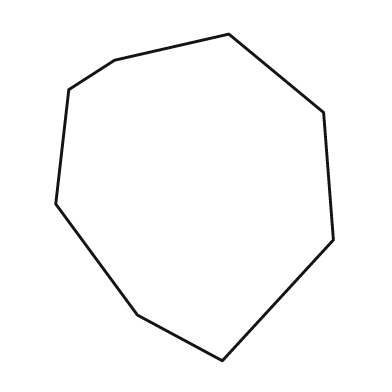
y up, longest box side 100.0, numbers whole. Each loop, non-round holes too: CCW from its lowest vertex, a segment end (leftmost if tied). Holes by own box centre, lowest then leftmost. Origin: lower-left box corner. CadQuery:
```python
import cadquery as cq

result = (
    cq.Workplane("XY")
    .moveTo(51.0, 0.0)
    .lineTo(85.0, 37.0)
    .lineTo(82.0, 76.0)
    .lineTo(53.0, 100.0)
    .lineTo(18.0, 92.0)
    .lineTo(4.0, 83.0)
    .lineTo(0.0, 48.0)
    .lineTo(25.0, 14.0)
    .close()
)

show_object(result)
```